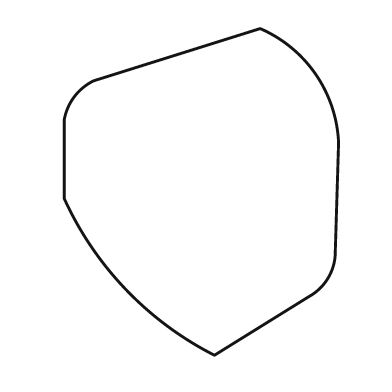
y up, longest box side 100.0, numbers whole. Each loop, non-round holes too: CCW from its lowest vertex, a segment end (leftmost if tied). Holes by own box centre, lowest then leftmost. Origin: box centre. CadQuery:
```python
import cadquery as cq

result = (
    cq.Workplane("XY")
    .moveTo(4.0, -50.0)
    .lineTo(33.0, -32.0)
    .threePointArc((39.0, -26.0), (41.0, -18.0))
    .lineTo(42.0, 15.0)
    .threePointArc((35.0, 36.0), (18.0, 50.0))
    .lineTo(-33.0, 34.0)
    .threePointArc((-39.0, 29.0), (-42.0, 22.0))
    .lineTo(-42.0, -2.0)
    .threePointArc((-23.0, -30.0), (4.0, -50.0))
    .close()
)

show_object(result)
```